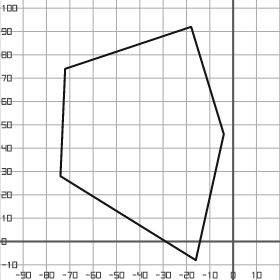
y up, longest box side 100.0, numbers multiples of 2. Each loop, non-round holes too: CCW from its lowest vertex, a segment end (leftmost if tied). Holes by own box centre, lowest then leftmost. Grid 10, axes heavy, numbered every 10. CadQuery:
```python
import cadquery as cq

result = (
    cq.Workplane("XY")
    .moveTo(-16.0, -8.0)
    .lineTo(-4.0, 46.0)
    .lineTo(-18.0, 92.0)
    .lineTo(-72.0, 74.0)
    .lineTo(-74.0, 28.0)
    .close()
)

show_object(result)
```